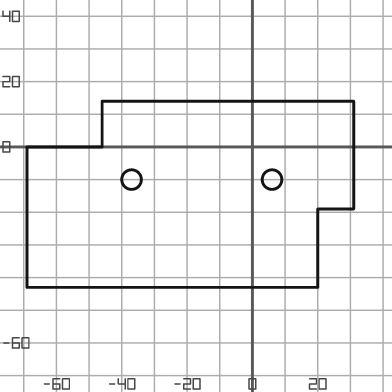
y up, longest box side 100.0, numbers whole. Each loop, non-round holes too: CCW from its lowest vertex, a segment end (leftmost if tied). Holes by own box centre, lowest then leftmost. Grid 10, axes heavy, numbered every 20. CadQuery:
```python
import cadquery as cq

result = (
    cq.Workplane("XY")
    .moveTo(-69.0, -43.0)
    .lineTo(20.0, -43.0)
    .lineTo(20.0, -19.0)
    .lineTo(31.0, -19.0)
    .lineTo(31.0, 14.0)
    .lineTo(-46.0, 14.0)
    .lineTo(-46.0, 0.0)
    .lineTo(-69.0, 0.0)
    .close()
    .moveTo(-37.0, -10.0)
    .circle(3.0)
    .moveTo(6.0, -10.0)
    .circle(3.0)
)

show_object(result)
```